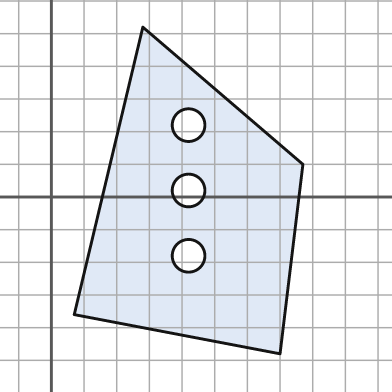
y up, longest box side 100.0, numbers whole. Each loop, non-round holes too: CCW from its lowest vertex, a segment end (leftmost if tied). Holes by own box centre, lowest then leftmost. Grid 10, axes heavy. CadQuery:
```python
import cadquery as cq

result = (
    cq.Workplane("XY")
    .moveTo(70.0, -48.0)
    .lineTo(77.0, 10.0)
    .lineTo(28.0, 52.0)
    .lineTo(7.0, -36.0)
    .close()
    .moveTo(42.0, -18.0)
    .circle(5.0)
    .moveTo(42.0, 2.0)
    .circle(5.0)
    .moveTo(42.0, 22.0)
    .circle(5.0)
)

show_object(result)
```